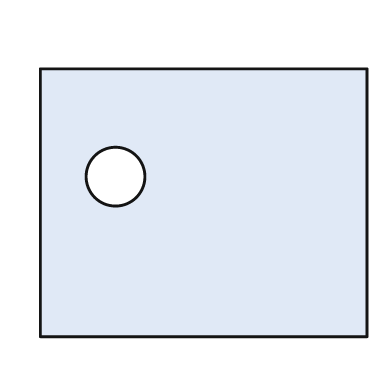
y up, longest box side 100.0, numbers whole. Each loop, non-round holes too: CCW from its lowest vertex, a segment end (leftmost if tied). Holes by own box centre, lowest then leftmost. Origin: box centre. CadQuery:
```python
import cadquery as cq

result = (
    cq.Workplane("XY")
    .moveTo(-50.0, -41.0)
    .lineTo(50.0, -41.0)
    .lineTo(50.0, 41.0)
    .lineTo(-50.0, 41.0)
    .close()
    .moveTo(-27.0, 8.0)
    .circle(9.0)
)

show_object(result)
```